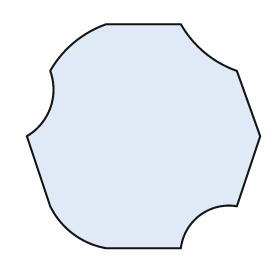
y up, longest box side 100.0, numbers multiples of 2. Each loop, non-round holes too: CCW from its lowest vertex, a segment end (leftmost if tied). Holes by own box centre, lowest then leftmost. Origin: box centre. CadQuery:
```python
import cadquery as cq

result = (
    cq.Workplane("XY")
    .moveTo(-16.0, -48.0)
    .lineTo(16.0, -48.0)
    .threePointArc((24.0, -34.0), (40.0, -30.0))
    .lineTo(50.0, 0.0)
    .lineTo(40.0, 28.0)
    .threePointArc((26.0, 36.0), (16.0, 48.0))
    .lineTo(-16.0, 48.0)
    .threePointArc((-30.0, 40.0), (-40.0, 28.0))
    .threePointArc((-40.0, 12.0), (-50.0, 0.0))
    .lineTo(-40.0, -30.0)
    .threePointArc((-30.0, -42.0), (-16.0, -48.0))
    .close()
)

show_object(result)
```